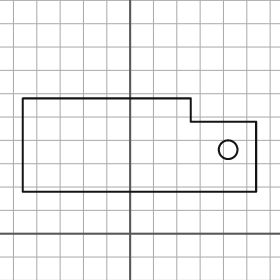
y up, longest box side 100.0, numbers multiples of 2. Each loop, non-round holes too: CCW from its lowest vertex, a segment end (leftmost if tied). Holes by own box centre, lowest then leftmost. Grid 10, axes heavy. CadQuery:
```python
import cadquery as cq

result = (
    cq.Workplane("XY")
    .moveTo(-46.0, 18.0)
    .lineTo(54.0, 18.0)
    .lineTo(54.0, 48.0)
    .lineTo(26.0, 48.0)
    .lineTo(26.0, 58.0)
    .lineTo(-46.0, 58.0)
    .close()
    .moveTo(42.0, 36.0)
    .circle(4.0)
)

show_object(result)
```